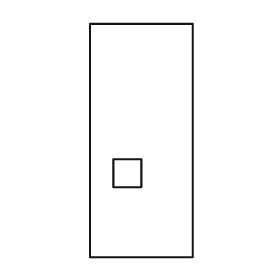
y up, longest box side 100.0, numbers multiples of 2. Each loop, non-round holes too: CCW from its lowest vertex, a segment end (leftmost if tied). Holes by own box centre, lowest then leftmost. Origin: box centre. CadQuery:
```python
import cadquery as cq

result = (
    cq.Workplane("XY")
    .moveTo(-22.0, -50.0)
    .lineTo(22.0, -50.0)
    .lineTo(22.0, 50.0)
    .lineTo(-22.0, 50.0)
    .close()
    .moveTo(-12.0, -20.0)
    .lineTo(0.0, -20.0)
    .lineTo(0.0, -8.0)
    .lineTo(-12.0, -8.0)
    .close()
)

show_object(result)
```